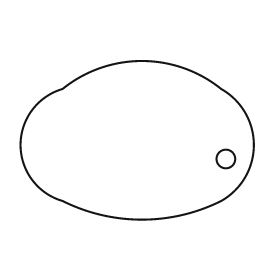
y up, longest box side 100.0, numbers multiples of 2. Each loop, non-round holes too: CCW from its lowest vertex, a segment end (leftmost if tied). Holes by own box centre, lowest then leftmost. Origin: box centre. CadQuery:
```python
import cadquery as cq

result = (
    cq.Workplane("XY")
    .moveTo(-32.0, -26.0)
    .threePointArc((2.0, -34.0), (36.0, -26.0))
    .threePointArc((50.0, -2.0), (36.0, 22.0))
    .threePointArc((2.0, 34.0), (-32.0, 22.0))
    .threePointArc((-50.0, -2.0), (-32.0, -26.0))
    .close()
    .moveTo(38.0, -8.0)
    .circle(4.0)
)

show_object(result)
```